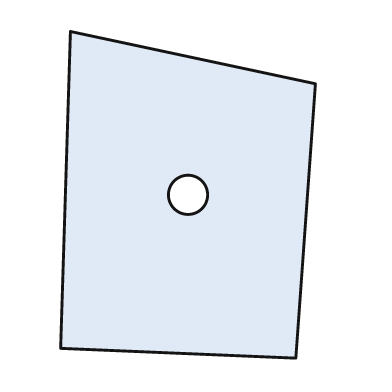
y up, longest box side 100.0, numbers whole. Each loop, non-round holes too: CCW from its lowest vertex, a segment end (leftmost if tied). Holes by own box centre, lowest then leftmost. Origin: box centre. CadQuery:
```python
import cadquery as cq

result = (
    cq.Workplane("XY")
    .moveTo(33.0, -50.0)
    .lineTo(39.0, 34.0)
    .lineTo(-36.0, 50.0)
    .lineTo(-39.0, -47.0)
    .close()
    .moveTo(0.0, 0.0)
    .circle(6.0)
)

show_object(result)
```